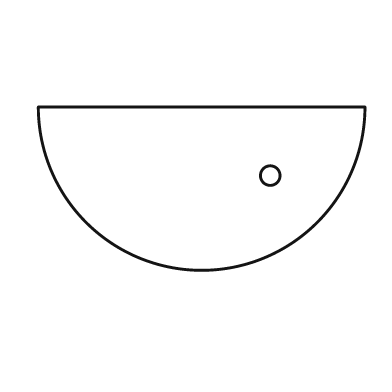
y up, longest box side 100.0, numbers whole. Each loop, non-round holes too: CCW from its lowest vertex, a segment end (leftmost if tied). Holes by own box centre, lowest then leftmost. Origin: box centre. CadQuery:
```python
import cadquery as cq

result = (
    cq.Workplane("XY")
    .moveTo(-50.0, 25.0)
    .threePointArc((0.0, -25.0), (50.0, 25.0))
    .close()
    .moveTo(21.0, 4.0)
    .circle(3.0)
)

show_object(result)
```